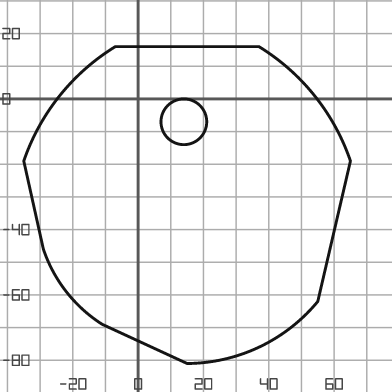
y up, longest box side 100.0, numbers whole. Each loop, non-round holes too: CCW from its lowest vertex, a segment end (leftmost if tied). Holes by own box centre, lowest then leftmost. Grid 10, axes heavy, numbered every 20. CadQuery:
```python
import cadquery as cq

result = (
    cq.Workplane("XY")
    .moveTo(15.0, -81.0)
    .threePointArc((37.0, -76.0), (55.0, -62.0))
    .lineTo(65.0, -19.0)
    .threePointArc((54.0, 1.0), (37.0, 16.0))
    .lineTo(-7.0, 16.0)
    .threePointArc((-24.0, 1.0), (-35.0, -19.0))
    .lineTo(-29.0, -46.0)
    .threePointArc((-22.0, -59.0), (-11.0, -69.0))
    .close()
    .moveTo(14.0, -7.0)
    .circle(7.0)
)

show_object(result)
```